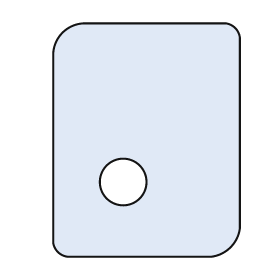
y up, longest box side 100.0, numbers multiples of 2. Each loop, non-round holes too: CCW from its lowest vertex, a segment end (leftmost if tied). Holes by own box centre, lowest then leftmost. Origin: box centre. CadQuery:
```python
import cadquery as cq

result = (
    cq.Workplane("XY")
    .moveTo(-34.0, -50.0)
    .lineTo(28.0, -50.0)
    .threePointArc((36.0, -46.0), (40.0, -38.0))
    .lineTo(40.0, 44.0)
    .threePointArc((38.0, 48.0), (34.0, 50.0))
    .lineTo(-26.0, 50.0)
    .threePointArc((-36.0, 46.0), (-40.0, 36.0))
    .lineTo(-40.0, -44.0)
    .threePointArc((-38.0, -48.0), (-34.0, -50.0))
    .close()
    .moveTo(-10.0, -18.0)
    .circle(10.0)
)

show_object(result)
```